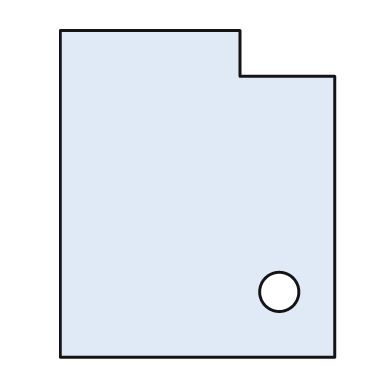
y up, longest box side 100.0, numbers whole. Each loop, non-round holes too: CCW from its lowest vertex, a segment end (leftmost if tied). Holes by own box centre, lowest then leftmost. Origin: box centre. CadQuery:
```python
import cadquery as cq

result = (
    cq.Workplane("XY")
    .moveTo(-42.0, -50.0)
    .lineTo(42.0, -50.0)
    .lineTo(42.0, 36.0)
    .lineTo(13.0, 36.0)
    .lineTo(13.0, 50.0)
    .lineTo(-42.0, 50.0)
    .close()
    .moveTo(25.0, -30.0)
    .circle(6.0)
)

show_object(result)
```